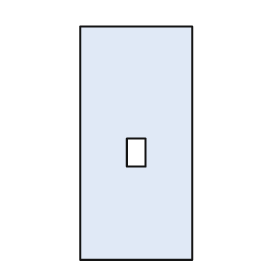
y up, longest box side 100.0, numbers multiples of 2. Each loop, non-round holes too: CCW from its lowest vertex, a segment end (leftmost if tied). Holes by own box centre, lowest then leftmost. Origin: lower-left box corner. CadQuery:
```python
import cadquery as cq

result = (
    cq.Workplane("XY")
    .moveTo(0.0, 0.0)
    .lineTo(48.0, 0.0)
    .lineTo(48.0, 100.0)
    .lineTo(0.0, 100.0)
    .close()
    .moveTo(20.0, 40.0)
    .lineTo(28.0, 40.0)
    .lineTo(28.0, 52.0)
    .lineTo(20.0, 52.0)
    .close()
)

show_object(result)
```